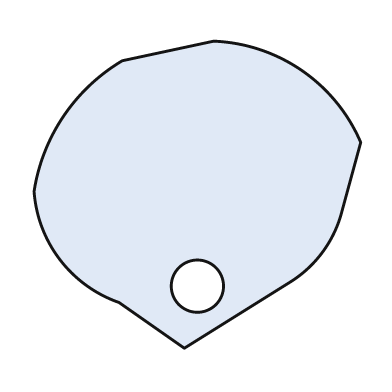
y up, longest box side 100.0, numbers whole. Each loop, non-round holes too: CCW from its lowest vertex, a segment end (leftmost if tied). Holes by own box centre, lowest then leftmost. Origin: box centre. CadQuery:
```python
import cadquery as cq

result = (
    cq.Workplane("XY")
    .moveTo(-4.0, -47.0)
    .lineTo(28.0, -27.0)
    .threePointArc((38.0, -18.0), (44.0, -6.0))
    .lineTo(50.0, 16.0)
    .threePointArc((32.0, 38.0), (5.0, 47.0))
    .lineTo(-23.0, 41.0)
    .threePointArc((-41.0, 24.0), (-50.0, 1.0))
    .threePointArc((-42.0, -20.0), (-24.0, -33.0))
    .close()
    .moveTo(0.0, -28.0)
    .circle(8.0)
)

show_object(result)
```